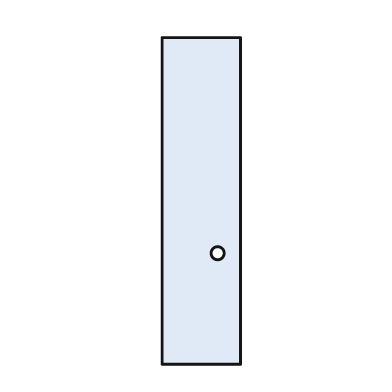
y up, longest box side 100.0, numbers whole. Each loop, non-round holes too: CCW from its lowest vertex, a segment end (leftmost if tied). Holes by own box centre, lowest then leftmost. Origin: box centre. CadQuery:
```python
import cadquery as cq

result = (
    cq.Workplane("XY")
    .moveTo(-12.0, -50.0)
    .lineTo(12.0, -50.0)
    .lineTo(12.0, 50.0)
    .lineTo(-12.0, 50.0)
    .close()
    .moveTo(5.0, -16.0)
    .circle(2.0)
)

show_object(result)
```